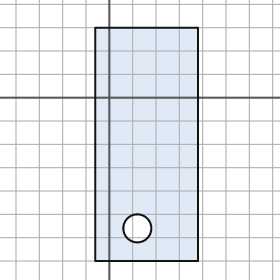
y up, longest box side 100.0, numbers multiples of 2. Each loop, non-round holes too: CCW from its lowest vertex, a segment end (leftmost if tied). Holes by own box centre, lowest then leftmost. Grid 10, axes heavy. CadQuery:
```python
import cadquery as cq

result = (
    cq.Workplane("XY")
    .moveTo(-6.0, -70.0)
    .lineTo(38.0, -70.0)
    .lineTo(38.0, 30.0)
    .lineTo(-6.0, 30.0)
    .close()
    .moveTo(12.0, -56.0)
    .circle(6.0)
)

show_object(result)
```